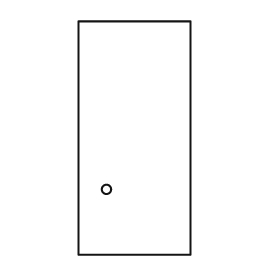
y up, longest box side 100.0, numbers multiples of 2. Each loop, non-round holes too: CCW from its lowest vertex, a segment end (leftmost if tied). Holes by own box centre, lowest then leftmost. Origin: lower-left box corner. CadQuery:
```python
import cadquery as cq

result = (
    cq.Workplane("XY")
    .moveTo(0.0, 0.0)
    .lineTo(48.0, 0.0)
    .lineTo(48.0, 100.0)
    .lineTo(0.0, 100.0)
    .close()
    .moveTo(12.0, 28.0)
    .circle(2.0)
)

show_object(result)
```